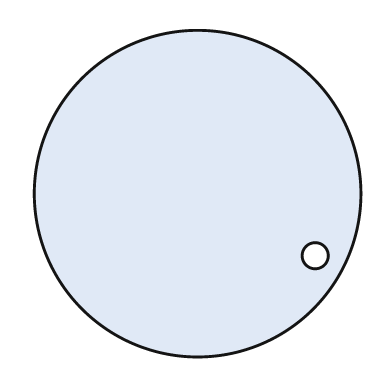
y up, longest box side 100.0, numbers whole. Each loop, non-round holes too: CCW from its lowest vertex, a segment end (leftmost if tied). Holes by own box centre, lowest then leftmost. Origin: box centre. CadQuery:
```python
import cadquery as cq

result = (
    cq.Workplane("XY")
    .moveTo(0.0, 0.0)
    .circle(50.0)
    .moveTo(36.0, -19.0)
    .circle(4.0)
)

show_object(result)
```